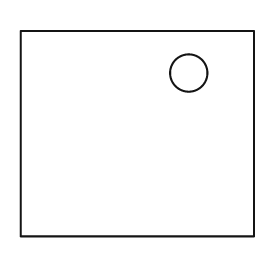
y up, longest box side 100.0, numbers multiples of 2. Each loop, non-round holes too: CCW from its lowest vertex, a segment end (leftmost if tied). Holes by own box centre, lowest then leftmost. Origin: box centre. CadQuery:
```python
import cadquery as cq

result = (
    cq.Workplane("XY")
    .moveTo(-50.0, -44.0)
    .lineTo(50.0, -44.0)
    .lineTo(50.0, 44.0)
    .lineTo(-50.0, 44.0)
    .close()
    .moveTo(22.0, 26.0)
    .circle(8.0)
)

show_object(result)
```